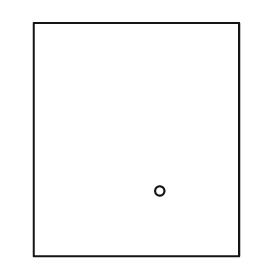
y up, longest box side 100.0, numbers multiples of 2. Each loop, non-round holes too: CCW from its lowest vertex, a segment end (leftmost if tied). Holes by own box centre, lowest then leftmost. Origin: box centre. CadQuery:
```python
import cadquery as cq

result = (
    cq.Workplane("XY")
    .moveTo(-44.0, -50.0)
    .lineTo(44.0, -50.0)
    .lineTo(44.0, 50.0)
    .lineTo(-44.0, 50.0)
    .close()
    .moveTo(10.0, -22.0)
    .circle(2.0)
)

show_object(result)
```